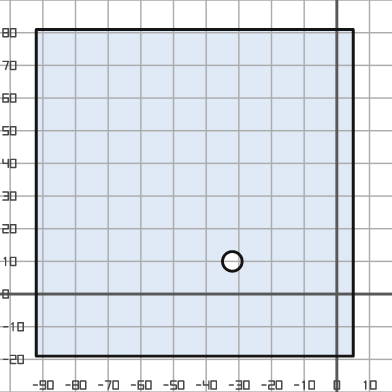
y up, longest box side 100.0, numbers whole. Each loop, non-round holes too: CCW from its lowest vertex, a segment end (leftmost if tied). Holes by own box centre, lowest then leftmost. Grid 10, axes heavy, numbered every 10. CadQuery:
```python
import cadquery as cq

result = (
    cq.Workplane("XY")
    .moveTo(-92.0, -19.0)
    .lineTo(5.0, -19.0)
    .lineTo(5.0, 81.0)
    .lineTo(-92.0, 81.0)
    .close()
    .moveTo(-32.0, 10.0)
    .circle(3.0)
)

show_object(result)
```